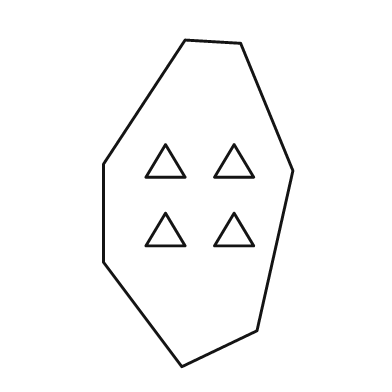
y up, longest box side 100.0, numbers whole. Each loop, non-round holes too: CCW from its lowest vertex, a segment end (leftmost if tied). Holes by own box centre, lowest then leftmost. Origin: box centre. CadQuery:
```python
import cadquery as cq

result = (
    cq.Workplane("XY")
    .moveTo(-5.0, -50.0)
    .lineTo(18.0, -39.0)
    .lineTo(29.0, 10.0)
    .lineTo(13.0, 49.0)
    .lineTo(-4.0, 50.0)
    .lineTo(-29.0, 12.0)
    .lineTo(-29.0, -18.0)
    .close()
    .moveTo(-16.0, -13.0)
    .lineTo(-4.0, -13.0)
    .lineTo(-10.0, -3.0)
    .close()
    .moveTo(5.0, -13.0)
    .lineTo(17.0, -13.0)
    .lineTo(11.0, -3.0)
    .close()
    .moveTo(-16.0, 8.0)
    .lineTo(-4.0, 8.0)
    .lineTo(-10.0, 18.0)
    .close()
    .moveTo(5.0, 8.0)
    .lineTo(17.0, 8.0)
    .lineTo(11.0, 18.0)
    .close()
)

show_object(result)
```